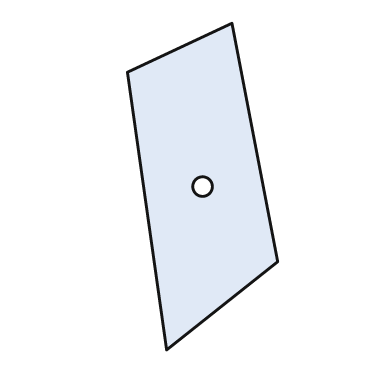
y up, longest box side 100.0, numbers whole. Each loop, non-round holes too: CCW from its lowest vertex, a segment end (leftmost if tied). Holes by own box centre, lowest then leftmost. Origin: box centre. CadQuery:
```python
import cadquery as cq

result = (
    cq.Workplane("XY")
    .moveTo(-11.0, -50.0)
    .lineTo(23.0, -23.0)
    .lineTo(9.0, 50.0)
    .lineTo(-23.0, 35.0)
    .close()
    .moveTo(0.0, 0.0)
    .circle(3.0)
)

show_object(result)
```